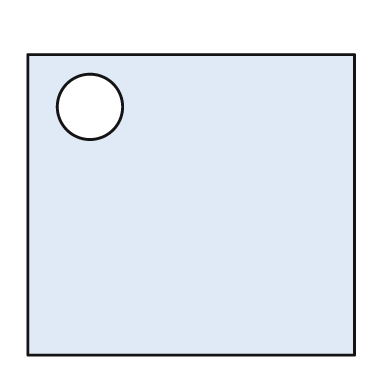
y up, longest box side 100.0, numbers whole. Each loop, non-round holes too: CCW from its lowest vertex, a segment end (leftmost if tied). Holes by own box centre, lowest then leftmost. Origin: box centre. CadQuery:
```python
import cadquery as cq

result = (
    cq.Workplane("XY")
    .moveTo(-50.0, -46.0)
    .lineTo(50.0, -46.0)
    .lineTo(50.0, 46.0)
    .lineTo(-50.0, 46.0)
    .close()
    .moveTo(-31.0, 30.0)
    .circle(10.0)
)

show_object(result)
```